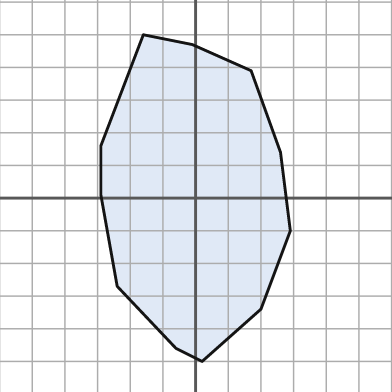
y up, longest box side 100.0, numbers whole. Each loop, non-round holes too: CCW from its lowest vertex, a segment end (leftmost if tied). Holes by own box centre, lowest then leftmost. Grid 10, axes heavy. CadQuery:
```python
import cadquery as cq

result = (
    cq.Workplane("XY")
    .moveTo(2.0, -50.0)
    .lineTo(20.0, -34.0)
    .lineTo(29.0, -10.0)
    .lineTo(26.0, 14.0)
    .lineTo(17.0, 39.0)
    .lineTo(-1.0, 47.0)
    .lineTo(-16.0, 50.0)
    .lineTo(-29.0, 16.0)
    .lineTo(-29.0, 1.0)
    .lineTo(-24.0, -27.0)
    .lineTo(-6.0, -46.0)
    .close()
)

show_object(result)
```